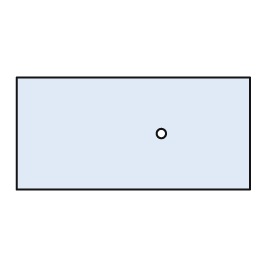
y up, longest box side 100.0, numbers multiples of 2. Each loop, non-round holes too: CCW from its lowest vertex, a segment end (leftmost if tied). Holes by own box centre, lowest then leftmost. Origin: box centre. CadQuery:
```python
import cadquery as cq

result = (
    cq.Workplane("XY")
    .moveTo(-50.0, -24.0)
    .lineTo(50.0, -24.0)
    .lineTo(50.0, 24.0)
    .lineTo(-50.0, 24.0)
    .close()
    .moveTo(12.0, 0.0)
    .circle(2.0)
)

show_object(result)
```